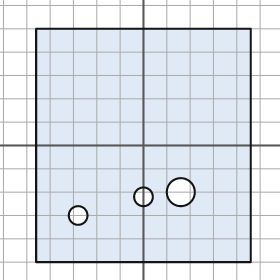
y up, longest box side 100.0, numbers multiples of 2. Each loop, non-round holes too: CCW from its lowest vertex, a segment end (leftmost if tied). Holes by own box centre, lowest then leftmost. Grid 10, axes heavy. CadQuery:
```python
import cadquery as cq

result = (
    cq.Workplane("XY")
    .moveTo(-46.0, -50.0)
    .lineTo(46.0, -50.0)
    .lineTo(46.0, 50.0)
    .lineTo(-46.0, 50.0)
    .close()
    .moveTo(-28.0, -30.0)
    .circle(4.0)
    .moveTo(0.0, -22.0)
    .circle(4.0)
    .moveTo(16.0, -20.0)
    .circle(6.0)
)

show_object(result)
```